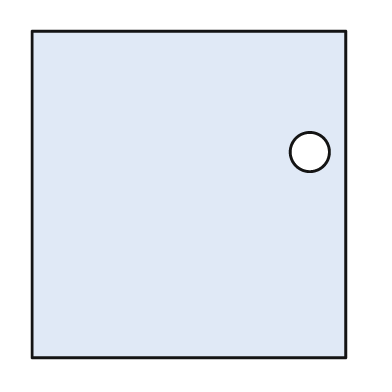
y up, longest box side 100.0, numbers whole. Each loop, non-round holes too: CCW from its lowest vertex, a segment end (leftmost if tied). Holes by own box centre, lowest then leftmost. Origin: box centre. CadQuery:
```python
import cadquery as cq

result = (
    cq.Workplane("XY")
    .moveTo(-48.0, -50.0)
    .lineTo(48.0, -50.0)
    .lineTo(48.0, 50.0)
    .lineTo(-48.0, 50.0)
    .close()
    .moveTo(37.0, 13.0)
    .circle(6.0)
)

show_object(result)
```